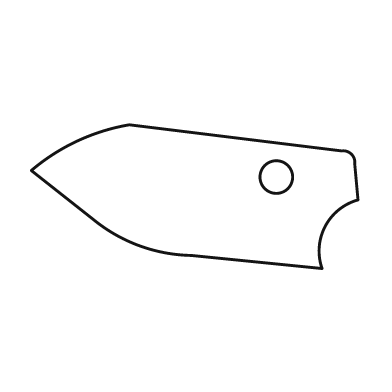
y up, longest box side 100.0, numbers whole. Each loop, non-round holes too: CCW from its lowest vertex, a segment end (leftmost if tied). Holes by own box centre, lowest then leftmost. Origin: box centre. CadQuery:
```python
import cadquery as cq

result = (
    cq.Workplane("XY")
    .moveTo(39.0, -22.0)
    .threePointArc((40.0, -9.0), (50.0, -1.0))
    .lineTo(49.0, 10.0)
    .threePointArc((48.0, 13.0), (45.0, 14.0))
    .lineTo(-20.0, 22.0)
    .threePointArc((-36.0, 17.0), (-50.0, 8.0))
    .lineTo(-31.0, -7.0)
    .threePointArc((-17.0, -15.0), (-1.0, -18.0))
    .close()
    .moveTo(25.0, 6.0)
    .circle(5.0)
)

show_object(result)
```